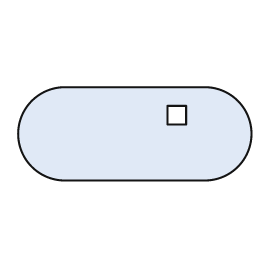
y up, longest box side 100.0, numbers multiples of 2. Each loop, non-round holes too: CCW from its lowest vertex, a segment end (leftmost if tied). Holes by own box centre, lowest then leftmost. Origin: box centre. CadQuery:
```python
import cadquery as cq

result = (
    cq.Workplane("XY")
    .moveTo(-30.0, -20.0)
    .lineTo(30.0, -20.0)
    .threePointArc((50.0, 0.0), (30.0, 20.0))
    .lineTo(-30.0, 20.0)
    .threePointArc((-50.0, 0.0), (-30.0, -20.0))
    .close()
    .moveTo(14.0, 4.0)
    .lineTo(22.0, 4.0)
    .lineTo(22.0, 12.0)
    .lineTo(14.0, 12.0)
    .close()
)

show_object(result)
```